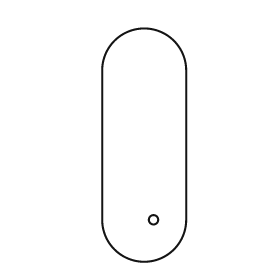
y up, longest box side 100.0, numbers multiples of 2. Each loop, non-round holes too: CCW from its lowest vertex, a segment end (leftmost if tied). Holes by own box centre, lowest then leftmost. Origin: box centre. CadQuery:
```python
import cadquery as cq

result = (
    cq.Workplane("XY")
    .moveTo(-18.0, -32.0)
    .threePointArc((0.0, -50.0), (18.0, -32.0))
    .lineTo(18.0, 32.0)
    .threePointArc((0.0, 50.0), (-18.0, 32.0))
    .close()
    .moveTo(4.0, -32.0)
    .circle(2.0)
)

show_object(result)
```